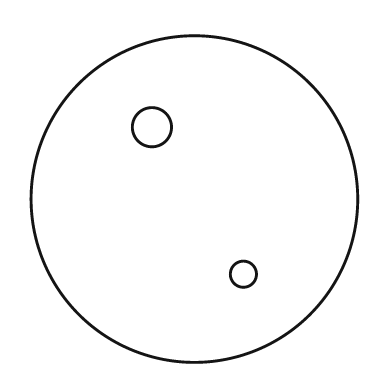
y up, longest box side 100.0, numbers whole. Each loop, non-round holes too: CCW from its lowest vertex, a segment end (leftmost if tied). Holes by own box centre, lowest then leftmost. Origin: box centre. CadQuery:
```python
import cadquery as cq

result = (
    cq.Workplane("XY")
    .moveTo(0.0, 0.0)
    .circle(50.0)
    .moveTo(15.0, -23.0)
    .circle(4.0)
    .moveTo(-13.0, 22.0)
    .circle(6.0)
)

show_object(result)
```